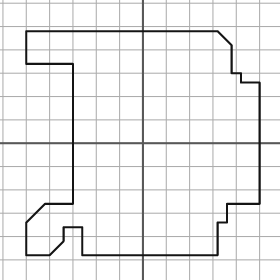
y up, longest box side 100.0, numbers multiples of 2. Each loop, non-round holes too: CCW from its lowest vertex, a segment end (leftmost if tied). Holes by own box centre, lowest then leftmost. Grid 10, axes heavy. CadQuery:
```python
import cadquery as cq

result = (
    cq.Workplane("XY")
    .moveTo(-50.0, -48.0)
    .lineTo(-40.0, -48.0)
    .lineTo(-34.0, -42.0)
    .lineTo(-34.0, -36.0)
    .lineTo(-26.0, -36.0)
    .lineTo(-26.0, -48.0)
    .lineTo(32.0, -48.0)
    .lineTo(32.0, -34.0)
    .lineTo(36.0, -34.0)
    .lineTo(36.0, -26.0)
    .lineTo(50.0, -26.0)
    .lineTo(50.0, 26.0)
    .lineTo(42.0, 26.0)
    .lineTo(42.0, 30.0)
    .lineTo(38.0, 30.0)
    .lineTo(38.0, 42.0)
    .lineTo(32.0, 48.0)
    .lineTo(-50.0, 48.0)
    .lineTo(-50.0, 34.0)
    .lineTo(-30.0, 34.0)
    .lineTo(-30.0, -26.0)
    .lineTo(-42.0, -26.0)
    .lineTo(-50.0, -34.0)
    .close()
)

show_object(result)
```